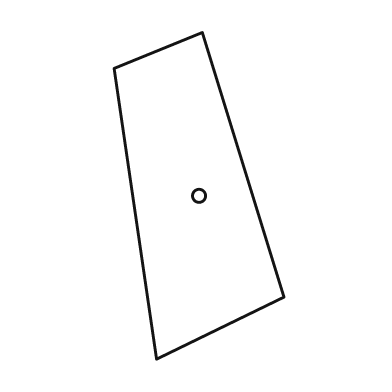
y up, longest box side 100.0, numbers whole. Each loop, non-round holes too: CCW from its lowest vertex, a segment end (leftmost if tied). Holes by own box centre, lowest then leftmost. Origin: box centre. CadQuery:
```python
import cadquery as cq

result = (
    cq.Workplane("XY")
    .moveTo(-13.0, -50.0)
    .lineTo(26.0, -31.0)
    .lineTo(1.0, 50.0)
    .lineTo(-26.0, 39.0)
    .close()
    .moveTo(0.0, 0.0)
    .circle(2.0)
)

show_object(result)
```